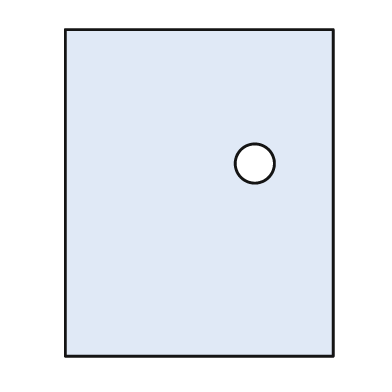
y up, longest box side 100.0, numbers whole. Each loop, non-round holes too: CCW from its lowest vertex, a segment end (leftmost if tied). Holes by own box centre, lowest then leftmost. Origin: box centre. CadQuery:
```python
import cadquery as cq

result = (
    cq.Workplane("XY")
    .moveTo(-41.0, -50.0)
    .lineTo(41.0, -50.0)
    .lineTo(41.0, 50.0)
    .lineTo(-41.0, 50.0)
    .close()
    .moveTo(17.0, 9.0)
    .circle(6.0)
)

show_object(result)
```